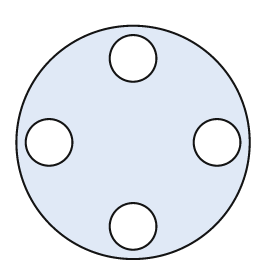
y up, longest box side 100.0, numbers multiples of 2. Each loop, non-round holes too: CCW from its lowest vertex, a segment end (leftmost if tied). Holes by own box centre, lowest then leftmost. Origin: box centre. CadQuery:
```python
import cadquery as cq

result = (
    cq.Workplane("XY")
    .moveTo(0.0, 0.0)
    .circle(50.0)
    .moveTo(0.0, -36.0)
    .circle(10.0)
    .moveTo(-36.0, 0.0)
    .circle(10.0)
    .moveTo(36.0, 0.0)
    .circle(10.0)
    .moveTo(0.0, 36.0)
    .circle(10.0)
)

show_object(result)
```